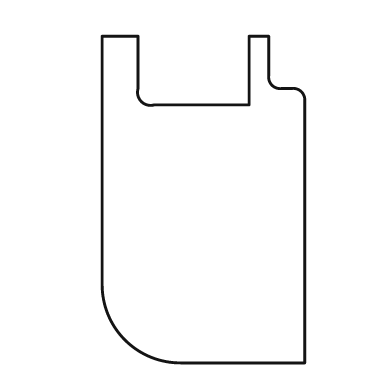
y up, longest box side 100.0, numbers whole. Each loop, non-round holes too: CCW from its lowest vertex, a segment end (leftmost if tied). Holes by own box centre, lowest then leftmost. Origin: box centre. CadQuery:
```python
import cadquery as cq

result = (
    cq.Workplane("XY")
    .moveTo(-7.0, -50.0)
    .lineTo(31.0, -50.0)
    .lineTo(31.0, 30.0)
    .threePointArc((30.0, 33.0), (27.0, 34.0))
    .lineTo(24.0, 34.0)
    .threePointArc((21.0, 35.0), (20.0, 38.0))
    .lineTo(20.0, 50.0)
    .lineTo(14.0, 50.0)
    .lineTo(14.0, 29.0)
    .lineTo(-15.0, 29.0)
    .threePointArc((-19.0, 30.0), (-20.0, 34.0))
    .lineTo(-20.0, 50.0)
    .lineTo(-31.0, 50.0)
    .lineTo(-31.0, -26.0)
    .threePointArc((-24.0, -43.0), (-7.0, -50.0))
    .close()
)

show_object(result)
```